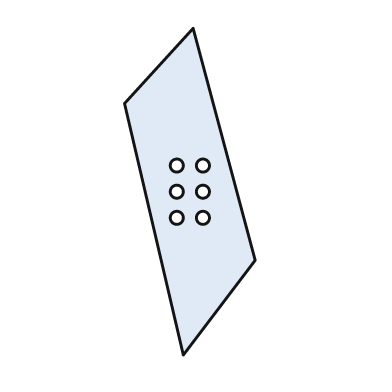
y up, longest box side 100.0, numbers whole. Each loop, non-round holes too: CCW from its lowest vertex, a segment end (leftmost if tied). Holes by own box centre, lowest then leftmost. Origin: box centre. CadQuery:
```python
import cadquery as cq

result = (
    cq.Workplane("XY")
    .moveTo(-2.0, -50.0)
    .lineTo(20.0, -21.0)
    .lineTo(1.0, 50.0)
    .lineTo(-20.0, 27.0)
    .close()
    .moveTo(-4.0, -8.0)
    .circle(2.0)
    .moveTo(4.0, -8.0)
    .circle(2.0)
    .moveTo(-4.0, 0.0)
    .circle(2.0)
    .moveTo(4.0, 0.0)
    .circle(2.0)
    .moveTo(-4.0, 8.0)
    .circle(2.0)
    .moveTo(4.0, 8.0)
    .circle(2.0)
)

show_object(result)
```